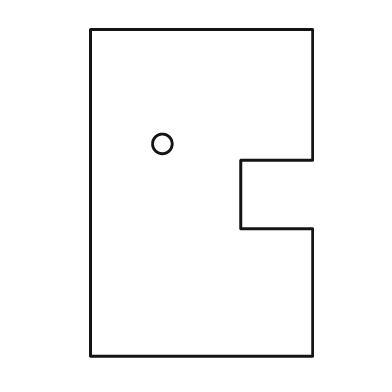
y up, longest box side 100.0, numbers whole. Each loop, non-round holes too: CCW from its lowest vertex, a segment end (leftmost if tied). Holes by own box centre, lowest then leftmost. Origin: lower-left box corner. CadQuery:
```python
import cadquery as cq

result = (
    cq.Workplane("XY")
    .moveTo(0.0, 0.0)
    .lineTo(68.0, 0.0)
    .lineTo(68.0, 39.0)
    .lineTo(46.0, 39.0)
    .lineTo(46.0, 60.0)
    .lineTo(68.0, 60.0)
    .lineTo(68.0, 100.0)
    .lineTo(0.0, 100.0)
    .close()
    .moveTo(22.0, 65.0)
    .circle(3.0)
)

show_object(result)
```